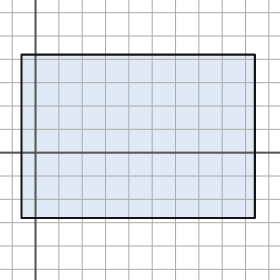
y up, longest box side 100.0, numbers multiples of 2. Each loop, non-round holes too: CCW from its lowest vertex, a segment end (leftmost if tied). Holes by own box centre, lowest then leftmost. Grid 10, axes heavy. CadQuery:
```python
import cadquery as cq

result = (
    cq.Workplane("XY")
    .moveTo(-6.0, -28.0)
    .lineTo(94.0, -28.0)
    .lineTo(94.0, 42.0)
    .lineTo(-6.0, 42.0)
    .close()
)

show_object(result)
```